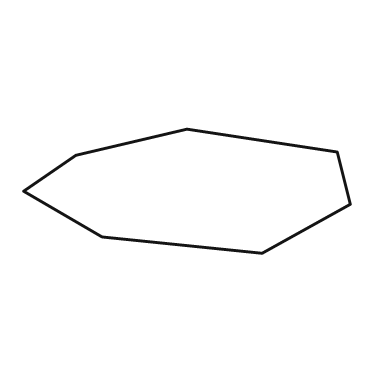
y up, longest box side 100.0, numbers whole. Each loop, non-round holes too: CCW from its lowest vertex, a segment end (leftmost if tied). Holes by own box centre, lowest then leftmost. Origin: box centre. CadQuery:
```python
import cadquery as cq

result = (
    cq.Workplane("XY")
    .moveTo(23.0, -19.0)
    .lineTo(50.0, -4.0)
    .lineTo(46.0, 12.0)
    .lineTo(0.0, 19.0)
    .lineTo(-34.0, 11.0)
    .lineTo(-50.0, 0.0)
    .lineTo(-26.0, -14.0)
    .close()
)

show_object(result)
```